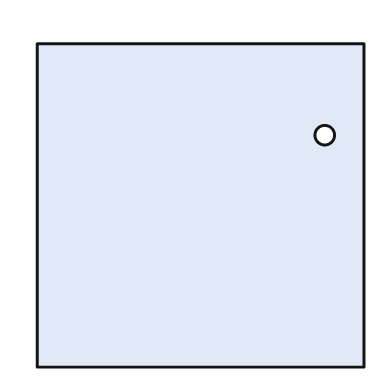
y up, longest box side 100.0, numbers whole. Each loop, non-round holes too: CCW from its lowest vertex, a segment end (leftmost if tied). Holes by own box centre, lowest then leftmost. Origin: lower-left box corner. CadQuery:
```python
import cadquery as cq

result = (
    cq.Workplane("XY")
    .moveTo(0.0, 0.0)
    .lineTo(100.0, 0.0)
    .lineTo(100.0, 99.0)
    .lineTo(0.0, 99.0)
    .close()
    .moveTo(88.0, 71.0)
    .circle(3.0)
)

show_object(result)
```